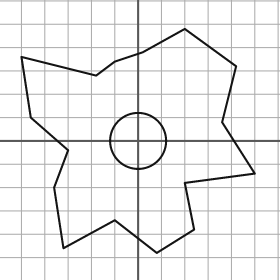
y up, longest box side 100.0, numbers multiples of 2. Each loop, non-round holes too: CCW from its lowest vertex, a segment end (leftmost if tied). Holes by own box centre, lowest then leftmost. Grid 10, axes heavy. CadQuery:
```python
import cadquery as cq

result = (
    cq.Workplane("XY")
    .moveTo(8.0, -48.0)
    .lineTo(24.0, -38.0)
    .lineTo(20.0, -18.0)
    .lineTo(50.0, -14.0)
    .lineTo(36.0, 8.0)
    .lineTo(42.0, 32.0)
    .lineTo(20.0, 48.0)
    .lineTo(2.0, 38.0)
    .lineTo(-10.0, 34.0)
    .lineTo(-18.0, 28.0)
    .lineTo(-50.0, 36.0)
    .lineTo(-46.0, 10.0)
    .lineTo(-30.0, -4.0)
    .lineTo(-36.0, -20.0)
    .lineTo(-32.0, -46.0)
    .lineTo(-10.0, -34.0)
    .close()
    .moveTo(0.0, 0.0)
    .circle(12.0)
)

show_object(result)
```